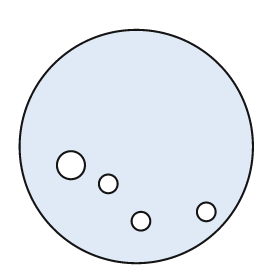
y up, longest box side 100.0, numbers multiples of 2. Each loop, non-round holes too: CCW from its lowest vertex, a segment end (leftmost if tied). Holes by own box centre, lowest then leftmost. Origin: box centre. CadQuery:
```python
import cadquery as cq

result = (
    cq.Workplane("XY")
    .moveTo(0.0, 0.0)
    .circle(50.0)
    .moveTo(2.0, -32.0)
    .circle(4.0)
    .moveTo(30.0, -28.0)
    .circle(4.0)
    .moveTo(-12.0, -16.0)
    .circle(4.0)
    .moveTo(-28.0, -8.0)
    .circle(6.0)
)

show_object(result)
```